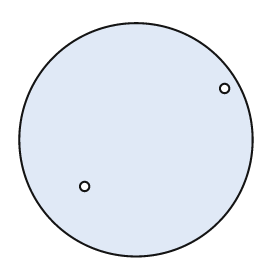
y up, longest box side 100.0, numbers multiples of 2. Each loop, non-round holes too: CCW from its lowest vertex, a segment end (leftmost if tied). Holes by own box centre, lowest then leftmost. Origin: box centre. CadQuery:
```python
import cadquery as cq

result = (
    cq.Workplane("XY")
    .moveTo(0.0, 0.0)
    .circle(50.0)
    .moveTo(-22.0, -20.0)
    .circle(2.0)
    .moveTo(38.0, 22.0)
    .circle(2.0)
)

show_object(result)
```